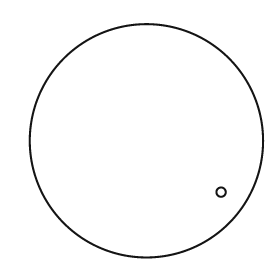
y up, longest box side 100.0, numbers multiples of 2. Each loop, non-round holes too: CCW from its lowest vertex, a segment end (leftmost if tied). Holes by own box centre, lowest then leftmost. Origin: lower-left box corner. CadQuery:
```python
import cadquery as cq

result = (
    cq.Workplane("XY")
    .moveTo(50.0, 50.0)
    .circle(50.0)
    .moveTo(82.0, 28.0)
    .circle(2.0)
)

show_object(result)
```